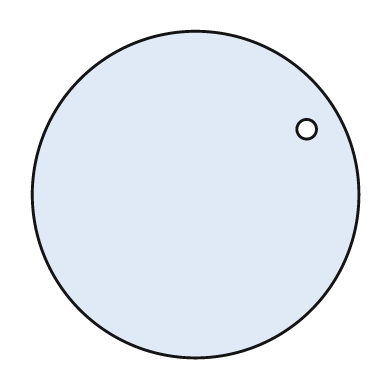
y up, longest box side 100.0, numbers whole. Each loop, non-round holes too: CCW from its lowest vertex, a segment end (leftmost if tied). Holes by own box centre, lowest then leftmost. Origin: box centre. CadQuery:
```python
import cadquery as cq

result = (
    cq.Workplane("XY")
    .moveTo(0.0, 0.0)
    .circle(50.0)
    .moveTo(34.0, 20.0)
    .circle(3.0)
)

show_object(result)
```